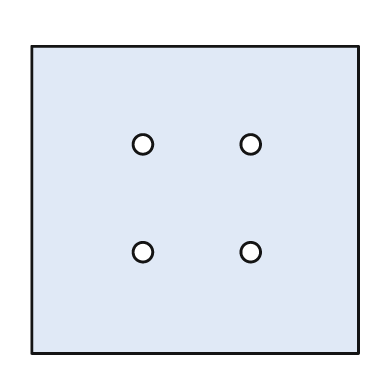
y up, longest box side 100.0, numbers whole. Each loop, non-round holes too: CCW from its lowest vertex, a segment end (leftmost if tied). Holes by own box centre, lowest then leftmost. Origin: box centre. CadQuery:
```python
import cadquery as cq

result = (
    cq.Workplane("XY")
    .moveTo(-50.0, -47.0)
    .lineTo(50.0, -47.0)
    .lineTo(50.0, 47.0)
    .lineTo(-50.0, 47.0)
    .close()
    .moveTo(-16.0, -16.0)
    .circle(3.0)
    .moveTo(17.0, -16.0)
    .circle(3.0)
    .moveTo(-16.0, 17.0)
    .circle(3.0)
    .moveTo(17.0, 17.0)
    .circle(3.0)
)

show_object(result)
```